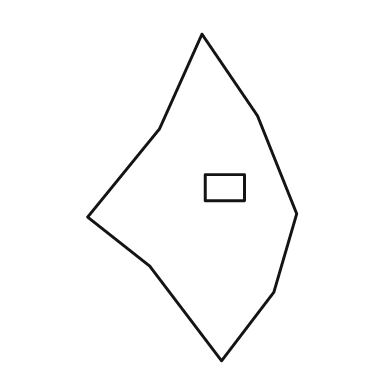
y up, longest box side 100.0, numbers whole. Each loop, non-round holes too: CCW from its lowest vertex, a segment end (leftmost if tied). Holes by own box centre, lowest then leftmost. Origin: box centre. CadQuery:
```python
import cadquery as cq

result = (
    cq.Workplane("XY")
    .moveTo(9.0, -50.0)
    .lineTo(25.0, -29.0)
    .lineTo(32.0, -5.0)
    .lineTo(20.0, 25.0)
    .lineTo(3.0, 50.0)
    .lineTo(-10.0, 21.0)
    .lineTo(-32.0, -6.0)
    .lineTo(-13.0, -21.0)
    .close()
    .moveTo(4.0, -1.0)
    .lineTo(16.0, -1.0)
    .lineTo(16.0, 7.0)
    .lineTo(4.0, 7.0)
    .close()
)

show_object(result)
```